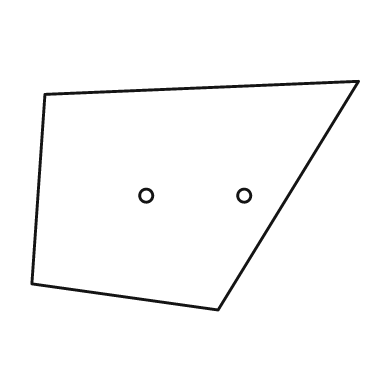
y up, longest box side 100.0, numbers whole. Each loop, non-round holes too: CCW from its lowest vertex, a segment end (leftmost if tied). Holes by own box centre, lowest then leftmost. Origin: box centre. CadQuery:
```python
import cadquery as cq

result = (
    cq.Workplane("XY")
    .moveTo(7.0, -35.0)
    .lineTo(50.0, 35.0)
    .lineTo(-46.0, 31.0)
    .lineTo(-50.0, -27.0)
    .close()
    .moveTo(-15.0, 0.0)
    .circle(2.0)
    .moveTo(15.0, 0.0)
    .circle(2.0)
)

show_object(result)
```